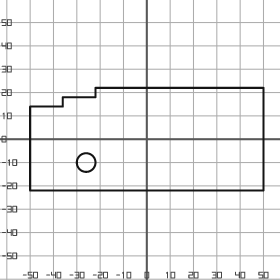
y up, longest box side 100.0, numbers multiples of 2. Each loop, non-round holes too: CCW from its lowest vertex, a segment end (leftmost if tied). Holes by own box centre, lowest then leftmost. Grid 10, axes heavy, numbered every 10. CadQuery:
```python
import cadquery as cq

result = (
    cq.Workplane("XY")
    .moveTo(-50.0, -22.0)
    .lineTo(50.0, -22.0)
    .lineTo(50.0, 22.0)
    .lineTo(-22.0, 22.0)
    .lineTo(-22.0, 18.0)
    .lineTo(-36.0, 18.0)
    .lineTo(-36.0, 14.0)
    .lineTo(-50.0, 14.0)
    .close()
    .moveTo(-26.0, -10.0)
    .circle(4.0)
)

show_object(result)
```